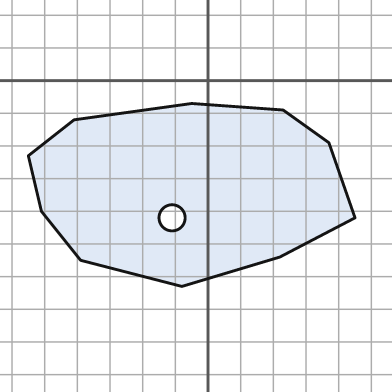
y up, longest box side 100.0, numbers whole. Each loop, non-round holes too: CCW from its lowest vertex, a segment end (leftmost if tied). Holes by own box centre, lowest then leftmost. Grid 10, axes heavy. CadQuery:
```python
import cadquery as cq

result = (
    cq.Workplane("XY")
    .moveTo(-8.0, -63.0)
    .lineTo(22.0, -54.0)
    .lineTo(45.0, -42.0)
    .lineTo(37.0, -19.0)
    .lineTo(23.0, -9.0)
    .lineTo(-5.0, -7.0)
    .lineTo(-41.0, -12.0)
    .lineTo(-55.0, -23.0)
    .lineTo(-51.0, -40.0)
    .lineTo(-39.0, -55.0)
    .close()
    .moveTo(-11.0, -42.0)
    .circle(4.0)
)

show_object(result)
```